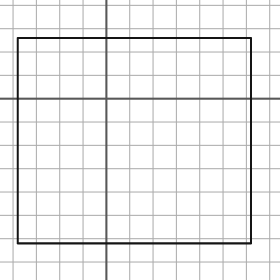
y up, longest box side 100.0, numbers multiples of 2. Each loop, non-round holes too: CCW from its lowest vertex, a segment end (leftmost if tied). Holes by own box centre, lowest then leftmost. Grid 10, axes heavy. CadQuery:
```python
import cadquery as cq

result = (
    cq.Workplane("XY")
    .moveTo(-38.0, -62.0)
    .lineTo(62.0, -62.0)
    .lineTo(62.0, 26.0)
    .lineTo(-38.0, 26.0)
    .close()
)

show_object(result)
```